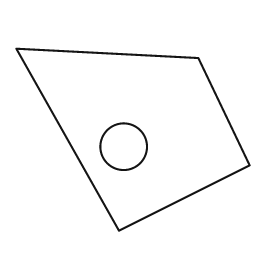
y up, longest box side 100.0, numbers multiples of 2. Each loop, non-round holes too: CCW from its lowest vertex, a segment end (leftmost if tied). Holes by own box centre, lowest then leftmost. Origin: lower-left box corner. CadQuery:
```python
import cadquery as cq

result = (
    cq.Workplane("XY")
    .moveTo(44.0, 0.0)
    .lineTo(100.0, 28.0)
    .lineTo(78.0, 74.0)
    .lineTo(0.0, 78.0)
    .close()
    .moveTo(46.0, 36.0)
    .circle(10.0)
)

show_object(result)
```